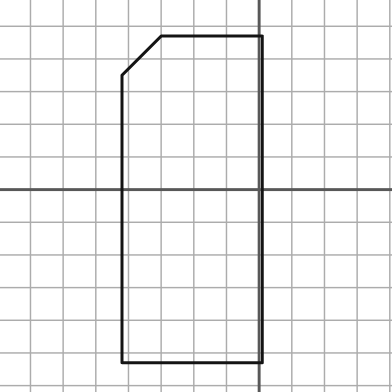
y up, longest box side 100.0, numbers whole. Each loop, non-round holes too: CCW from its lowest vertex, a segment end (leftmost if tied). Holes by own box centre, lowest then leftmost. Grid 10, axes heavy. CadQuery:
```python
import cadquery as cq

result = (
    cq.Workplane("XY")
    .moveTo(-42.0, -53.0)
    .lineTo(1.0, -53.0)
    .lineTo(1.0, 47.0)
    .lineTo(-30.0, 47.0)
    .lineTo(-42.0, 35.0)
    .close()
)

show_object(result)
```